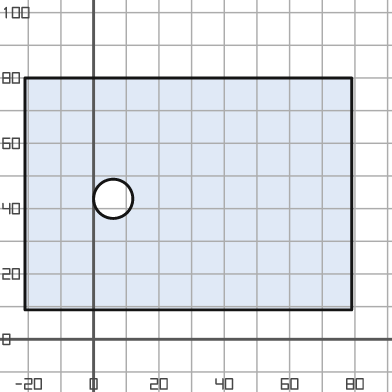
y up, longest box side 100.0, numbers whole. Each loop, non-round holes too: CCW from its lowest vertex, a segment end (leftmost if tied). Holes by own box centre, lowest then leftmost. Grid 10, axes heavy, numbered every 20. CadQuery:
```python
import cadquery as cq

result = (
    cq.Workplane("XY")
    .moveTo(-21.0, 9.0)
    .lineTo(79.0, 9.0)
    .lineTo(79.0, 80.0)
    .lineTo(-21.0, 80.0)
    .close()
    .moveTo(6.0, 43.0)
    .circle(6.0)
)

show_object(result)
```